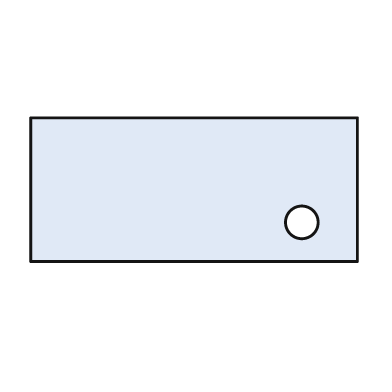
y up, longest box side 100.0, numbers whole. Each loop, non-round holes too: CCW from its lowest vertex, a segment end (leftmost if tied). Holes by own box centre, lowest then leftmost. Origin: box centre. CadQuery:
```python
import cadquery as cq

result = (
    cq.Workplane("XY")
    .moveTo(-50.0, -22.0)
    .lineTo(50.0, -22.0)
    .lineTo(50.0, 22.0)
    .lineTo(-50.0, 22.0)
    .close()
    .moveTo(33.0, -10.0)
    .circle(5.0)
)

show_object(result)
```